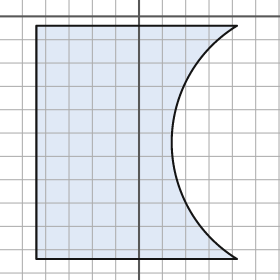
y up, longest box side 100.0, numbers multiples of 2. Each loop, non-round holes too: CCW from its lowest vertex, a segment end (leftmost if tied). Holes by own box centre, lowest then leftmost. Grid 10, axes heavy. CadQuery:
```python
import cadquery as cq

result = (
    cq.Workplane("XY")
    .moveTo(-44.0, -104.0)
    .lineTo(42.0, -104.0)
    .threePointArc((14.0, -54.0), (42.0, -4.0))
    .lineTo(-44.0, -4.0)
    .close()
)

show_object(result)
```